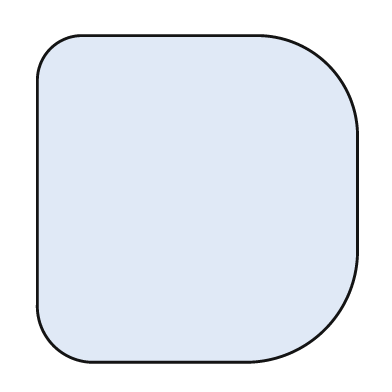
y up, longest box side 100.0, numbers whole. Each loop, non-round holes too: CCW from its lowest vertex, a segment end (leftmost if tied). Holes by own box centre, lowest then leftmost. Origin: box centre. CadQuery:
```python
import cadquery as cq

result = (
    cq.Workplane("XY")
    .moveTo(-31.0, -50.0)
    .lineTo(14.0, -50.0)
    .threePointArc((39.0, -40.0), (49.0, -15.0))
    .lineTo(49.0, 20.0)
    .threePointArc((40.0, 41.0), (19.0, 50.0))
    .lineTo(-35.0, 50.0)
    .threePointArc((-45.0, 46.0), (-49.0, 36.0))
    .lineTo(-49.0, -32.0)
    .threePointArc((-44.0, -45.0), (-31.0, -50.0))
    .close()
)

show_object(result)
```